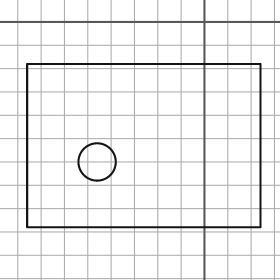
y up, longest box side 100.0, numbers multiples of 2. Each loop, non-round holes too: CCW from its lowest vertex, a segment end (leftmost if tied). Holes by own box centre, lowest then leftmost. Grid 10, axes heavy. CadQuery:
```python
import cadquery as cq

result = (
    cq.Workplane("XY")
    .moveTo(-76.0, -88.0)
    .lineTo(24.0, -88.0)
    .lineTo(24.0, -18.0)
    .lineTo(-76.0, -18.0)
    .close()
    .moveTo(-46.0, -60.0)
    .circle(8.0)
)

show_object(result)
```